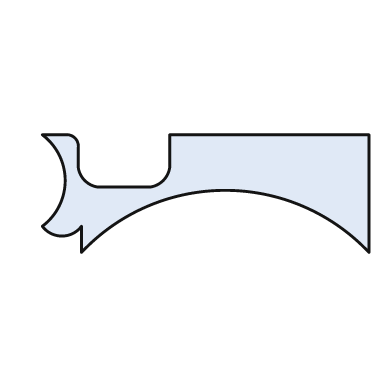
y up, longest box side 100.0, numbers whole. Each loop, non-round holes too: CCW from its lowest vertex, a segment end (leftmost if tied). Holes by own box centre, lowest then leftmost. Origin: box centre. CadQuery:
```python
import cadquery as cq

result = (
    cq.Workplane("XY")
    .moveTo(-38.0, -18.0)
    .threePointArc((6.0, 1.0), (50.0, -18.0))
    .lineTo(50.0, 18.0)
    .lineTo(-11.0, 18.0)
    .lineTo(-11.0, 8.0)
    .threePointArc((-13.0, 4.0), (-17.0, 2.0))
    .lineTo(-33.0, 2.0)
    .threePointArc((-37.0, 4.0), (-39.0, 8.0))
    .lineTo(-39.0, 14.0)
    .threePointArc((-40.0, 17.0), (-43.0, 18.0))
    .lineTo(-50.0, 18.0)
    .threePointArc((-43.0, 4.0), (-50.0, -10.0))
    .threePointArc((-44.0, -13.0), (-38.0, -10.0))
    .close()
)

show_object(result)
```